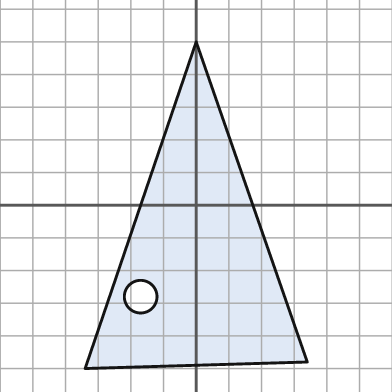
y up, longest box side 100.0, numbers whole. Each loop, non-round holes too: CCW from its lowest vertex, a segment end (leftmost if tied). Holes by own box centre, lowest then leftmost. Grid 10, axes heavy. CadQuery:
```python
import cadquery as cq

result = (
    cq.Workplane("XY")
    .moveTo(-34.0, -50.0)
    .lineTo(34.0, -48.0)
    .lineTo(0.0, 50.0)
    .close()
    .moveTo(-17.0, -28.0)
    .circle(5.0)
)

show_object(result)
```